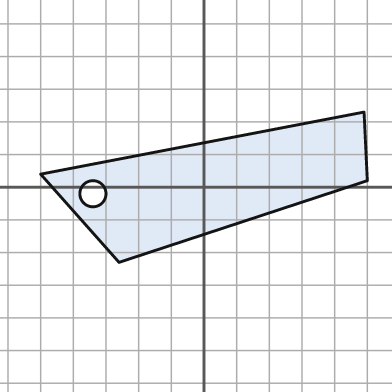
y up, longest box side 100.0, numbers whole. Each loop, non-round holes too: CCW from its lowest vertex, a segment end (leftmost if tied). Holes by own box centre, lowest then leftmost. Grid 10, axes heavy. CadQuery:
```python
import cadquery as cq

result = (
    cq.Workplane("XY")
    .moveTo(-26.0, -23.0)
    .lineTo(50.0, 2.0)
    .lineTo(49.0, 23.0)
    .lineTo(-50.0, 4.0)
    .close()
    .moveTo(-34.0, -2.0)
    .circle(4.0)
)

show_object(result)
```